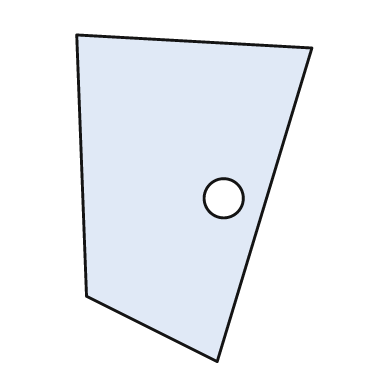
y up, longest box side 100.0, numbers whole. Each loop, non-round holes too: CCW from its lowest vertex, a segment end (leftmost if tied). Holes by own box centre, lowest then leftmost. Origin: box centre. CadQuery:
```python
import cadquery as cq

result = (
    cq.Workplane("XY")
    .moveTo(7.0, -50.0)
    .lineTo(36.0, 46.0)
    .lineTo(-36.0, 50.0)
    .lineTo(-33.0, -30.0)
    .close()
    .moveTo(9.0, 0.0)
    .circle(6.0)
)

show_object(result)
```